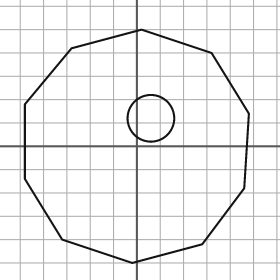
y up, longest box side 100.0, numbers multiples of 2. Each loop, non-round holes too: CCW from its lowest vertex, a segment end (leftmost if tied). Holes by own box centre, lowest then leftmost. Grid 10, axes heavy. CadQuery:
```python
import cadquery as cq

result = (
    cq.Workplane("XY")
    .moveTo(-2.0, -50.0)
    .lineTo(28.0, -42.0)
    .lineTo(46.0, -18.0)
    .lineTo(48.0, 14.0)
    .lineTo(32.0, 40.0)
    .lineTo(2.0, 50.0)
    .lineTo(-28.0, 42.0)
    .lineTo(-48.0, 18.0)
    .lineTo(-48.0, -14.0)
    .lineTo(-32.0, -40.0)
    .close()
    .moveTo(6.0, 12.0)
    .circle(10.0)
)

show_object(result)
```